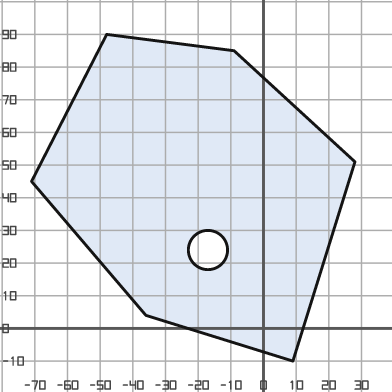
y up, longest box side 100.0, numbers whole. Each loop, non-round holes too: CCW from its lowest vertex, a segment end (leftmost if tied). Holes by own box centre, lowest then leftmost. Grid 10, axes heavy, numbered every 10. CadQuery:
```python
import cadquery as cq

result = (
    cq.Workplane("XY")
    .moveTo(9.0, -10.0)
    .lineTo(28.0, 51.0)
    .lineTo(-9.0, 85.0)
    .lineTo(-48.0, 90.0)
    .lineTo(-71.0, 45.0)
    .lineTo(-36.0, 4.0)
    .close()
    .moveTo(-17.0, 24.0)
    .circle(6.0)
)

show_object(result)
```